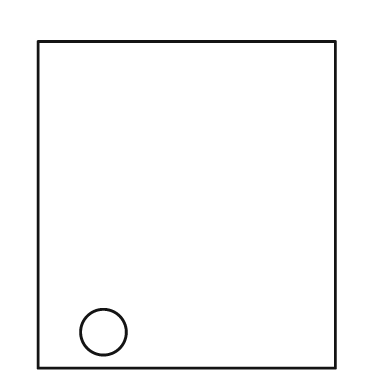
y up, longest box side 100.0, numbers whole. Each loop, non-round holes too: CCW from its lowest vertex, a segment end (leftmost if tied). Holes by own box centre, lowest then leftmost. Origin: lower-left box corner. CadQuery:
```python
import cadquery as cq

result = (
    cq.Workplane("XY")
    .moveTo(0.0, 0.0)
    .lineTo(91.0, 0.0)
    .lineTo(91.0, 100.0)
    .lineTo(0.0, 100.0)
    .close()
    .moveTo(20.0, 11.0)
    .circle(7.0)
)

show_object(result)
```